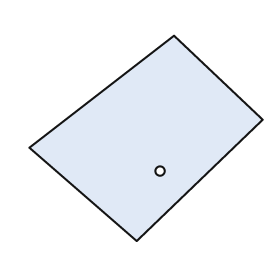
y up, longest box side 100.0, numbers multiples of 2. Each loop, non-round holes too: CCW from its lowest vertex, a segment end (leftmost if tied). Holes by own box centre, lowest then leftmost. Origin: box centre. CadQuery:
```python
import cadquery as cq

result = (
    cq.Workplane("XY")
    .moveTo(-4.0, -44.0)
    .lineTo(50.0, 8.0)
    .lineTo(12.0, 44.0)
    .lineTo(-50.0, -4.0)
    .close()
    .moveTo(6.0, -14.0)
    .circle(2.0)
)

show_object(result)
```